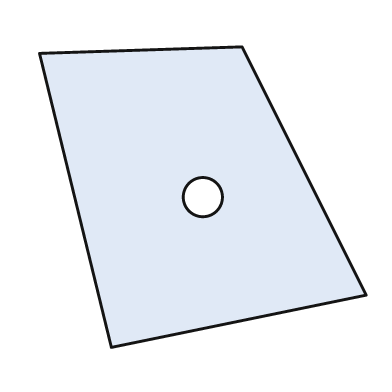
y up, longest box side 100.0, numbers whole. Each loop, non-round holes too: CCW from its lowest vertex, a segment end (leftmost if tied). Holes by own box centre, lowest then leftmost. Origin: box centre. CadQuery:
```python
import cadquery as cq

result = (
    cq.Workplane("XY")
    .moveTo(-28.0, -46.0)
    .lineTo(50.0, -30.0)
    .lineTo(12.0, 46.0)
    .lineTo(-50.0, 44.0)
    .close()
    .moveTo(0.0, 0.0)
    .circle(6.0)
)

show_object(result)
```